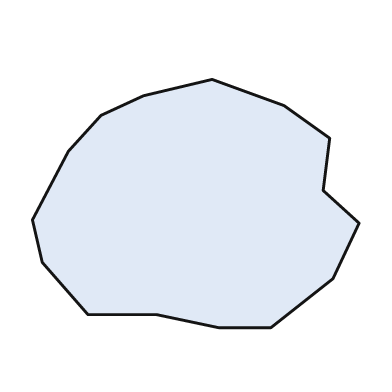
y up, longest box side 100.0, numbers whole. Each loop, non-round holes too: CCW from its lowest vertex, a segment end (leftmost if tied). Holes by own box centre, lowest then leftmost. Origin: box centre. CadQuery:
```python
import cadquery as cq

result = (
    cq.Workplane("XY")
    .moveTo(7.0, -38.0)
    .lineTo(23.0, -38.0)
    .lineTo(42.0, -23.0)
    .lineTo(50.0, -6.0)
    .lineTo(39.0, 4.0)
    .lineTo(41.0, 20.0)
    .lineTo(27.0, 30.0)
    .lineTo(5.0, 38.0)
    .lineTo(-16.0, 33.0)
    .lineTo(-29.0, 27.0)
    .lineTo(-39.0, 16.0)
    .lineTo(-50.0, -5.0)
    .lineTo(-47.0, -18.0)
    .lineTo(-33.0, -34.0)
    .lineTo(-12.0, -34.0)
    .close()
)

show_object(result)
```